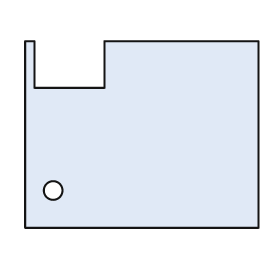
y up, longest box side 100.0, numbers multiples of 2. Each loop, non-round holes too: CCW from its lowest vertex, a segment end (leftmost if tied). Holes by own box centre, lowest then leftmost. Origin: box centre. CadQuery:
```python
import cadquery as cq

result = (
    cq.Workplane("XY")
    .moveTo(-50.0, -40.0)
    .lineTo(50.0, -40.0)
    .lineTo(50.0, 40.0)
    .lineTo(-16.0, 40.0)
    .lineTo(-16.0, 20.0)
    .lineTo(-46.0, 20.0)
    .lineTo(-46.0, 40.0)
    .lineTo(-50.0, 40.0)
    .close()
    .moveTo(-38.0, -24.0)
    .circle(4.0)
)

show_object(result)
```